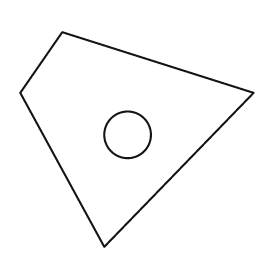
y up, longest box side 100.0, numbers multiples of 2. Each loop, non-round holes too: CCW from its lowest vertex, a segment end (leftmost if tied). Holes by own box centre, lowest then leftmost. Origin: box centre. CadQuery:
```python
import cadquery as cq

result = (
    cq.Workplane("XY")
    .moveTo(-14.0, -46.0)
    .lineTo(50.0, 20.0)
    .lineTo(-32.0, 46.0)
    .lineTo(-50.0, 20.0)
    .close()
    .moveTo(-4.0, 2.0)
    .circle(10.0)
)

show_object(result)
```